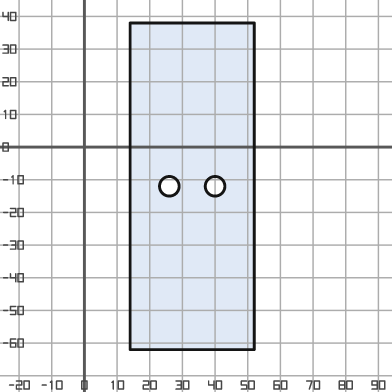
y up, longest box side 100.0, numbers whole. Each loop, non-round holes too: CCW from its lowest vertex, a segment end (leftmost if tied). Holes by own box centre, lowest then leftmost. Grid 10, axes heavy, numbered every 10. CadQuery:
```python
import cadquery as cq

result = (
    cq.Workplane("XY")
    .moveTo(14.0, -62.0)
    .lineTo(52.0, -62.0)
    .lineTo(52.0, 38.0)
    .lineTo(14.0, 38.0)
    .close()
    .moveTo(26.0, -12.0)
    .circle(3.0)
    .moveTo(40.0, -12.0)
    .circle(3.0)
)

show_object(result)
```